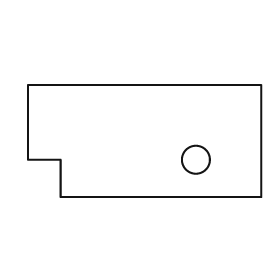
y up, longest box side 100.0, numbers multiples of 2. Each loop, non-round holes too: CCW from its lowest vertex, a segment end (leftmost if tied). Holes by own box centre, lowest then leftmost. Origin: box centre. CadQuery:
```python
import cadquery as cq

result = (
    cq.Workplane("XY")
    .moveTo(-36.0, -24.0)
    .lineTo(50.0, -24.0)
    .lineTo(50.0, 24.0)
    .lineTo(-50.0, 24.0)
    .lineTo(-50.0, -8.0)
    .lineTo(-36.0, -8.0)
    .close()
    .moveTo(22.0, -8.0)
    .circle(6.0)
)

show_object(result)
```